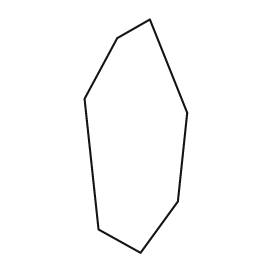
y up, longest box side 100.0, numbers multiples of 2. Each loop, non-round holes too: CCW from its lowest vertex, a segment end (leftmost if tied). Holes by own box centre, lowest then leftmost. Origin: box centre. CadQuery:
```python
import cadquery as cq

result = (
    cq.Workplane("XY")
    .moveTo(2.0, -50.0)
    .lineTo(18.0, -28.0)
    .lineTo(22.0, 10.0)
    .lineTo(6.0, 50.0)
    .lineTo(-8.0, 42.0)
    .lineTo(-22.0, 16.0)
    .lineTo(-16.0, -40.0)
    .close()
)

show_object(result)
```